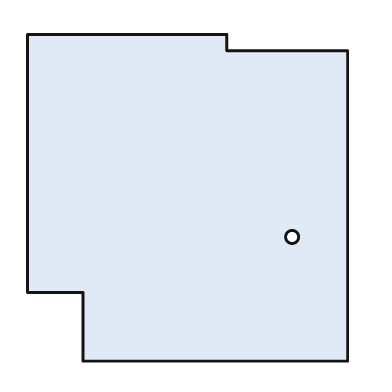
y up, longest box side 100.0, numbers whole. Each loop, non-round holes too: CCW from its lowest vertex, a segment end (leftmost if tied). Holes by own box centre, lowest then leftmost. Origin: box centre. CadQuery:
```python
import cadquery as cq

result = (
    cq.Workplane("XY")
    .moveTo(-32.0, -50.0)
    .lineTo(49.0, -50.0)
    .lineTo(49.0, 45.0)
    .lineTo(12.0, 45.0)
    .lineTo(12.0, 50.0)
    .lineTo(-49.0, 50.0)
    .lineTo(-49.0, -29.0)
    .lineTo(-32.0, -29.0)
    .close()
    .moveTo(32.0, -12.0)
    .circle(2.0)
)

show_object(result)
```